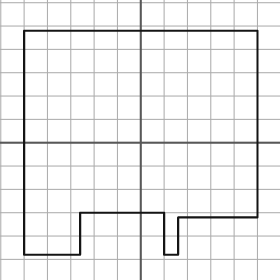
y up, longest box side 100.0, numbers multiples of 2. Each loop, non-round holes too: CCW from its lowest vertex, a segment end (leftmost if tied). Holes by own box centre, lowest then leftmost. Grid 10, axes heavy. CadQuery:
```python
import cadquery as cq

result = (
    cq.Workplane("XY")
    .moveTo(-50.0, -48.0)
    .lineTo(-26.0, -48.0)
    .lineTo(-26.0, -30.0)
    .lineTo(10.0, -30.0)
    .lineTo(10.0, -48.0)
    .lineTo(16.0, -48.0)
    .lineTo(16.0, -32.0)
    .lineTo(50.0, -32.0)
    .lineTo(50.0, 48.0)
    .lineTo(-50.0, 48.0)
    .close()
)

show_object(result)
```